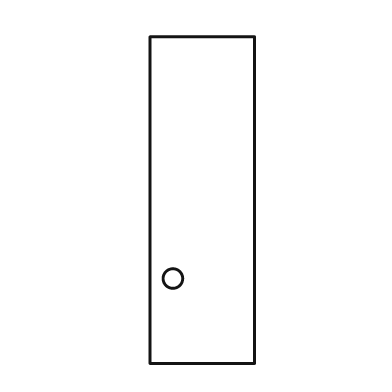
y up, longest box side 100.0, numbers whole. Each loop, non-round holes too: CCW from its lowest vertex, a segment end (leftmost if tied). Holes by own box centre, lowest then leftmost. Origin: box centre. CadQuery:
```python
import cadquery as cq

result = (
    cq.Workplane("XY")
    .moveTo(-16.0, -50.0)
    .lineTo(16.0, -50.0)
    .lineTo(16.0, 50.0)
    .lineTo(-16.0, 50.0)
    .close()
    .moveTo(-9.0, -24.0)
    .circle(3.0)
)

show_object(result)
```